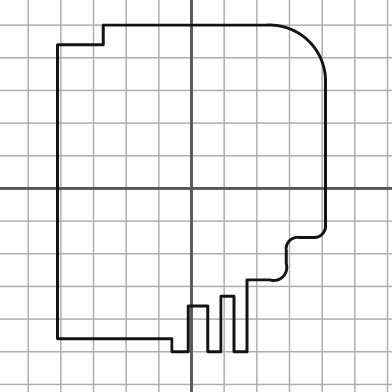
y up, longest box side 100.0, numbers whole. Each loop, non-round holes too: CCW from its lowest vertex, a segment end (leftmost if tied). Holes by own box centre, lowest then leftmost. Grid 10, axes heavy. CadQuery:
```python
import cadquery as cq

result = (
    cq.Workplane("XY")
    .moveTo(-6.0, -50.0)
    .lineTo(-1.0, -50.0)
    .lineTo(-1.0, -36.0)
    .lineTo(5.0, -36.0)
    .lineTo(5.0, -50.0)
    .lineTo(9.0, -50.0)
    .lineTo(9.0, -33.0)
    .lineTo(13.0, -33.0)
    .lineTo(13.0, -50.0)
    .lineTo(17.0, -50.0)
    .lineTo(17.0, -28.0)
    .lineTo(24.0, -28.0)
    .threePointArc((28.0, -27.0), (29.0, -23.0))
    .lineTo(29.0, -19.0)
    .threePointArc((30.0, -16.0), (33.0, -15.0))
    .lineTo(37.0, -15.0)
    .threePointArc((40.0, -14.0), (41.0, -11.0))
    .lineTo(41.0, 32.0)
    .threePointArc((36.0, 45.0), (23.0, 50.0))
    .lineTo(-27.0, 50.0)
    .lineTo(-27.0, 44.0)
    .lineTo(-41.0, 44.0)
    .lineTo(-41.0, -46.0)
    .lineTo(-6.0, -46.0)
    .close()
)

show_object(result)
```